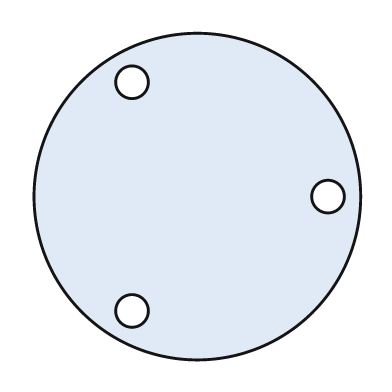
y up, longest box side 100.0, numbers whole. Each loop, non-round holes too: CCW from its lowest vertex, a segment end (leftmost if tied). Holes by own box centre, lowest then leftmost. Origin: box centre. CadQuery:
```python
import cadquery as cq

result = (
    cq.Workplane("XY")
    .moveTo(0.0, 0.0)
    .circle(50.0)
    .moveTo(-20.0, -35.0)
    .circle(5.0)
    .moveTo(40.0, 0.0)
    .circle(5.0)
    .moveTo(-20.0, 35.0)
    .circle(5.0)
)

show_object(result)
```